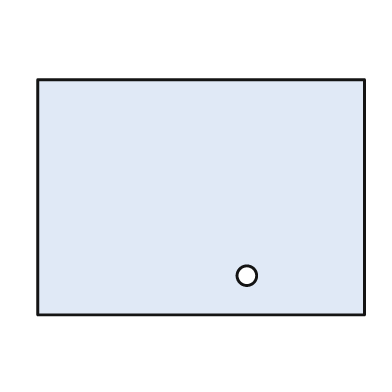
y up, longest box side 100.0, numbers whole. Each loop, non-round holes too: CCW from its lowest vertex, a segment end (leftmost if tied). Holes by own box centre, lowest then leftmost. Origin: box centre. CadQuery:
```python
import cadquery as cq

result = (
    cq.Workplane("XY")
    .moveTo(-50.0, -36.0)
    .lineTo(50.0, -36.0)
    .lineTo(50.0, 36.0)
    .lineTo(-50.0, 36.0)
    .close()
    .moveTo(14.0, -24.0)
    .circle(3.0)
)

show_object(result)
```